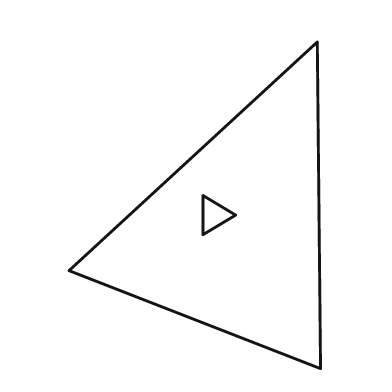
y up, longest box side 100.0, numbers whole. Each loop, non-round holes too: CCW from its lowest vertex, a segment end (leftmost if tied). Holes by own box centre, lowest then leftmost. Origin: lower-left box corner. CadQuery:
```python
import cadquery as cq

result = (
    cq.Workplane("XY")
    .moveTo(77.0, 0.0)
    .lineTo(76.0, 100.0)
    .lineTo(0.0, 30.0)
    .close()
    .moveTo(41.0, 41.0)
    .lineTo(51.0, 47.0)
    .lineTo(41.0, 53.0)
    .close()
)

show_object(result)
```